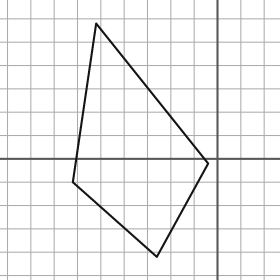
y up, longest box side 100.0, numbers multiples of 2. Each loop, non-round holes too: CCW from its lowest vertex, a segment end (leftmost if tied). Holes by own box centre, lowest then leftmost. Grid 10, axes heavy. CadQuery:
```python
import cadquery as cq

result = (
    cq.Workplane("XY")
    .moveTo(-26.0, -42.0)
    .lineTo(-4.0, -2.0)
    .lineTo(-52.0, 58.0)
    .lineTo(-62.0, -10.0)
    .close()
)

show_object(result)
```